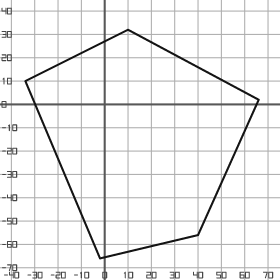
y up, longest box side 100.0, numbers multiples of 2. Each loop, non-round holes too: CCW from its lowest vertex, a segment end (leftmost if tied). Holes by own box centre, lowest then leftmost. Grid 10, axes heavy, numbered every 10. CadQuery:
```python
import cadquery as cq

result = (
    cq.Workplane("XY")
    .moveTo(-2.0, -66.0)
    .lineTo(40.0, -56.0)
    .lineTo(66.0, 2.0)
    .lineTo(10.0, 32.0)
    .lineTo(-34.0, 10.0)
    .close()
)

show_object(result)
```